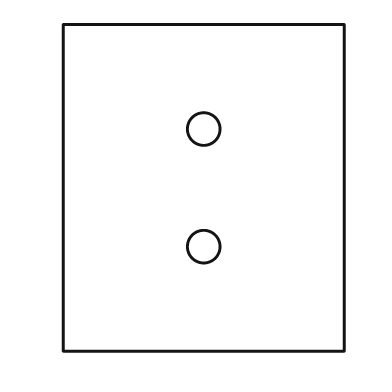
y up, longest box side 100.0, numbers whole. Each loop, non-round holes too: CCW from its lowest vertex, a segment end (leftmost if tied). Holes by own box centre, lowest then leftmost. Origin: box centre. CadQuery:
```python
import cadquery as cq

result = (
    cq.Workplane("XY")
    .moveTo(-43.0, -50.0)
    .lineTo(43.0, -50.0)
    .lineTo(43.0, 50.0)
    .lineTo(-43.0, 50.0)
    .close()
    .moveTo(0.0, -18.0)
    .circle(5.0)
    .moveTo(0.0, 18.0)
    .circle(5.0)
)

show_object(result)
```